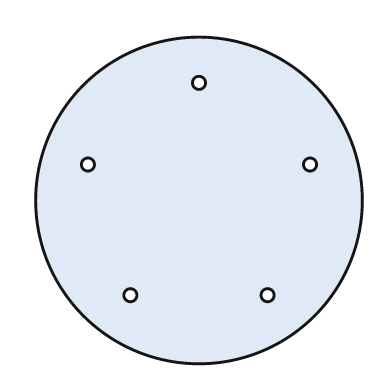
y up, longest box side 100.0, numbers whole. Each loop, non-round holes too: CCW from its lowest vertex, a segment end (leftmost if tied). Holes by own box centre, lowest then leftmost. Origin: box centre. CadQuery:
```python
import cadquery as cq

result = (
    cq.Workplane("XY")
    .moveTo(0.0, 0.0)
    .circle(50.0)
    .moveTo(-21.0, -29.0)
    .circle(2.0)
    .moveTo(21.0, -29.0)
    .circle(2.0)
    .moveTo(-34.0, 11.0)
    .circle(2.0)
    .moveTo(34.0, 11.0)
    .circle(2.0)
    .moveTo(0.0, 36.0)
    .circle(2.0)
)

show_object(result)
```